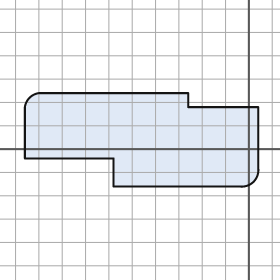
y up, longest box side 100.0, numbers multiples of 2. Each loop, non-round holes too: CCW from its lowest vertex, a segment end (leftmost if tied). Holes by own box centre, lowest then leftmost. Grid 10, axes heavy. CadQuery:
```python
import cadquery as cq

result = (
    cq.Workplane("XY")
    .moveTo(-58.0, -16.0)
    .lineTo(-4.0, -16.0)
    .threePointArc((2.0, -14.0), (4.0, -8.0))
    .lineTo(4.0, 18.0)
    .lineTo(-26.0, 18.0)
    .lineTo(-26.0, 24.0)
    .lineTo(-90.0, 24.0)
    .threePointArc((-94.0, 22.0), (-96.0, 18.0))
    .lineTo(-96.0, -4.0)
    .lineTo(-58.0, -4.0)
    .close()
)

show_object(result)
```